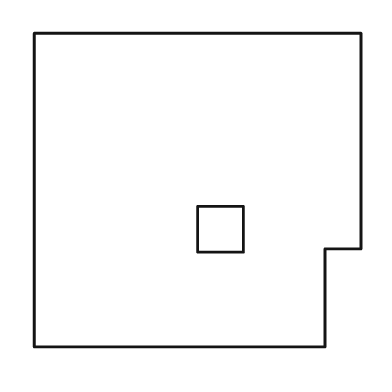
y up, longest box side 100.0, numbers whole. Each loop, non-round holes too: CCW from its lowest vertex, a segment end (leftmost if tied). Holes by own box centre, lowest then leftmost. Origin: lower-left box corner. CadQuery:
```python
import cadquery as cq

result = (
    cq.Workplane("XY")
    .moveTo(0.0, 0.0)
    .lineTo(89.0, 0.0)
    .lineTo(89.0, 30.0)
    .lineTo(100.0, 30.0)
    .lineTo(100.0, 96.0)
    .lineTo(0.0, 96.0)
    .close()
    .moveTo(50.0, 29.0)
    .lineTo(64.0, 29.0)
    .lineTo(64.0, 43.0)
    .lineTo(50.0, 43.0)
    .close()
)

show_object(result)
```